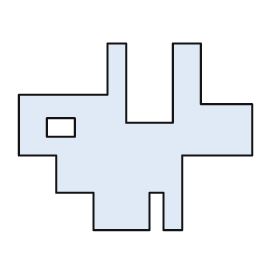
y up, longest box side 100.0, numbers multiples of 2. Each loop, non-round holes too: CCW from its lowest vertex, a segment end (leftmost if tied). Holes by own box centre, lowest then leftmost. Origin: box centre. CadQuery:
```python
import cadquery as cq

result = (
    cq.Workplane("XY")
    .moveTo(-18.0, -40.0)
    .lineTo(6.0, -40.0)
    .lineTo(6.0, -24.0)
    .lineTo(12.0, -24.0)
    .lineTo(12.0, -40.0)
    .lineTo(20.0, -40.0)
    .lineTo(20.0, -8.0)
    .lineTo(50.0, -8.0)
    .lineTo(50.0, 14.0)
    .lineTo(28.0, 14.0)
    .lineTo(28.0, 40.0)
    .lineTo(16.0, 40.0)
    .lineTo(16.0, 6.0)
    .lineTo(-4.0, 6.0)
    .lineTo(-4.0, 40.0)
    .lineTo(-12.0, 40.0)
    .lineTo(-12.0, 18.0)
    .lineTo(-50.0, 18.0)
    .lineTo(-50.0, -8.0)
    .lineTo(-34.0, -8.0)
    .lineTo(-34.0, -24.0)
    .lineTo(-18.0, -24.0)
    .close()
    .moveTo(-38.0, 0.0)
    .lineTo(-26.0, 0.0)
    .lineTo(-26.0, 8.0)
    .lineTo(-38.0, 8.0)
    .close()
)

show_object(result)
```